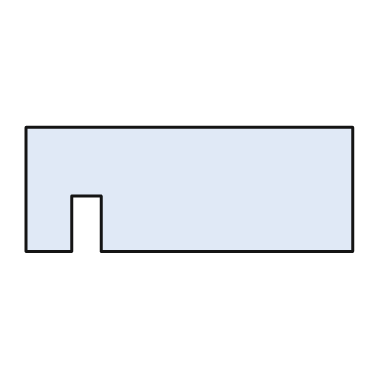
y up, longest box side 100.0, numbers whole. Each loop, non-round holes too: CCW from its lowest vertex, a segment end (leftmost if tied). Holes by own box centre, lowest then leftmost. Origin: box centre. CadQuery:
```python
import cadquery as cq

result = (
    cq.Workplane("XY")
    .moveTo(-50.0, -19.0)
    .lineTo(-36.0, -19.0)
    .lineTo(-36.0, -2.0)
    .lineTo(-27.0, -2.0)
    .lineTo(-27.0, -19.0)
    .lineTo(50.0, -19.0)
    .lineTo(50.0, 19.0)
    .lineTo(-50.0, 19.0)
    .close()
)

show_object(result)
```